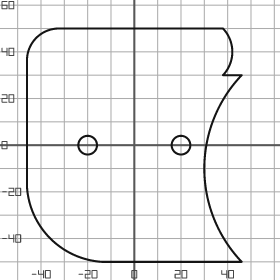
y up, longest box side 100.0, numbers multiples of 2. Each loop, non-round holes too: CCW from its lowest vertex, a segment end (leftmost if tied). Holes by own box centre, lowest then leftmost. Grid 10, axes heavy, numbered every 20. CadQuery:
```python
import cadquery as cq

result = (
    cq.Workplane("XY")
    .moveTo(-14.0, -50.0)
    .lineTo(46.0, -50.0)
    .threePointArc((30.0, -10.0), (46.0, 30.0))
    .lineTo(38.0, 30.0)
    .threePointArc((42.0, 40.0), (38.0, 50.0))
    .lineTo(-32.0, 50.0)
    .threePointArc((-42.0, 46.0), (-46.0, 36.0))
    .lineTo(-46.0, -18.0)
    .threePointArc((-36.0, -40.0), (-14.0, -50.0))
    .close()
    .moveTo(-20.0, 0.0)
    .circle(4.0)
    .moveTo(20.0, 0.0)
    .circle(4.0)
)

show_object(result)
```